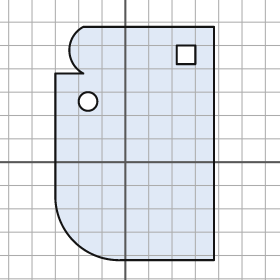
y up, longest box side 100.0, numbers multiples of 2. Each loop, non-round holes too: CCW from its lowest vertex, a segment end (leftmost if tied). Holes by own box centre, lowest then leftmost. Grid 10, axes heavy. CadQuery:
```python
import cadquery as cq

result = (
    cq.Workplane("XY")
    .moveTo(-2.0, -42.0)
    .lineTo(38.0, -42.0)
    .lineTo(38.0, 58.0)
    .lineTo(-18.0, 58.0)
    .threePointArc((-24.0, 48.0), (-18.0, 38.0))
    .lineTo(-30.0, 38.0)
    .lineTo(-30.0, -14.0)
    .threePointArc((-22.0, -34.0), (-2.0, -42.0))
    .close()
    .moveTo(-16.0, 26.0)
    .circle(4.0)
    .moveTo(22.0, 42.0)
    .lineTo(30.0, 42.0)
    .lineTo(30.0, 50.0)
    .lineTo(22.0, 50.0)
    .close()
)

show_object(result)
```